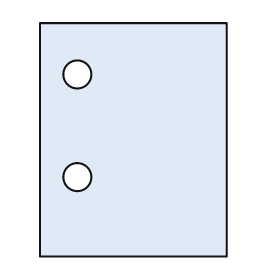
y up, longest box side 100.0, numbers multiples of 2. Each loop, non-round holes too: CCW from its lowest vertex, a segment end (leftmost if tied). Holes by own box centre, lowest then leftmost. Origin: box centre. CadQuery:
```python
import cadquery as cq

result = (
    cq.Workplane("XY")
    .moveTo(-40.0, -50.0)
    .lineTo(40.0, -50.0)
    .lineTo(40.0, 50.0)
    .lineTo(-40.0, 50.0)
    .close()
    .moveTo(-24.0, -16.0)
    .circle(6.0)
    .moveTo(-24.0, 28.0)
    .circle(6.0)
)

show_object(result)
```